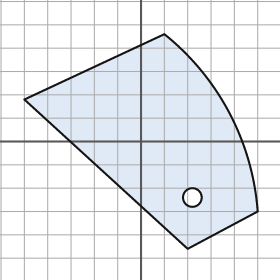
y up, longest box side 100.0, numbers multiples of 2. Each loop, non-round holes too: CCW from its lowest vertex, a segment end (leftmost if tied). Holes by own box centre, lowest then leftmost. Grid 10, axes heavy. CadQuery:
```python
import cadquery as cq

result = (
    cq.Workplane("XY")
    .moveTo(20.0, -46.0)
    .lineTo(50.0, -30.0)
    .threePointArc((38.0, 12.0), (10.0, 46.0))
    .lineTo(-50.0, 18.0)
    .close()
    .moveTo(22.0, -24.0)
    .circle(4.0)
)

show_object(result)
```